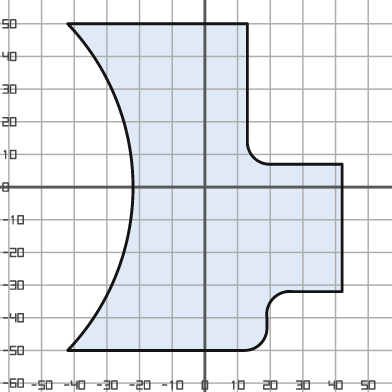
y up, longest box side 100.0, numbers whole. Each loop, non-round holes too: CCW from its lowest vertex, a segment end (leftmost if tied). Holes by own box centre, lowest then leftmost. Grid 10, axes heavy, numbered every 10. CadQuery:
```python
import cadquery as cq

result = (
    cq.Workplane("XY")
    .moveTo(-42.0, -50.0)
    .lineTo(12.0, -50.0)
    .threePointArc((17.0, -48.0), (19.0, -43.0))
    .lineTo(19.0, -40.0)
    .threePointArc((21.0, -34.0), (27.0, -32.0))
    .lineTo(42.0, -32.0)
    .lineTo(42.0, 7.0)
    .lineTo(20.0, 7.0)
    .threePointArc((15.0, 9.0), (13.0, 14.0))
    .lineTo(13.0, 50.0)
    .lineTo(-42.0, 50.0)
    .threePointArc((-22.0, 0.0), (-42.0, -50.0))
    .close()
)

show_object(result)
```